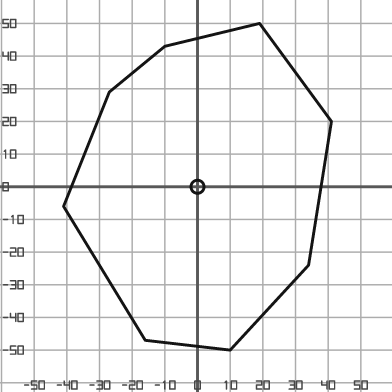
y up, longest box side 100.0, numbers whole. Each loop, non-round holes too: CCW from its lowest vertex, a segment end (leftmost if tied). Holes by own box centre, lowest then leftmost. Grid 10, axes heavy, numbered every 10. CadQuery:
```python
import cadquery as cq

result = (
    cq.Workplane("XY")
    .moveTo(10.0, -50.0)
    .lineTo(34.0, -24.0)
    .lineTo(41.0, 20.0)
    .lineTo(19.0, 50.0)
    .lineTo(-10.0, 43.0)
    .lineTo(-27.0, 29.0)
    .lineTo(-41.0, -6.0)
    .lineTo(-16.0, -47.0)
    .close()
    .moveTo(0.0, 0.0)
    .circle(2.0)
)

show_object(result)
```